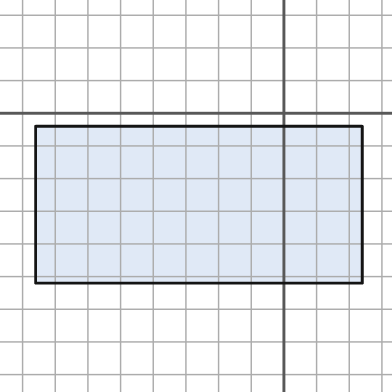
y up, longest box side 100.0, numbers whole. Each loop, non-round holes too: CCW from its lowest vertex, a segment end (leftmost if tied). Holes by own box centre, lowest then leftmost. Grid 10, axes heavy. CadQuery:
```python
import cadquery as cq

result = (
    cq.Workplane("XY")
    .moveTo(-76.0, -52.0)
    .lineTo(24.0, -52.0)
    .lineTo(24.0, -4.0)
    .lineTo(-76.0, -4.0)
    .close()
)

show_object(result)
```